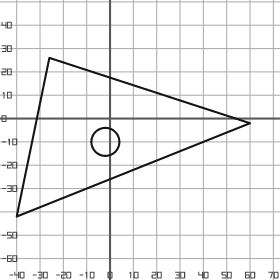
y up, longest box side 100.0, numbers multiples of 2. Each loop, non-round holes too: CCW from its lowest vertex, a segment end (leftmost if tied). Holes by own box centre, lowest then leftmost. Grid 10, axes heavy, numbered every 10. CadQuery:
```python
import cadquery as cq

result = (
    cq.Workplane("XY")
    .moveTo(-40.0, -42.0)
    .lineTo(60.0, -2.0)
    .lineTo(-26.0, 26.0)
    .close()
    .moveTo(-2.0, -10.0)
    .circle(6.0)
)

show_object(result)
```